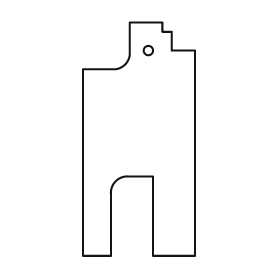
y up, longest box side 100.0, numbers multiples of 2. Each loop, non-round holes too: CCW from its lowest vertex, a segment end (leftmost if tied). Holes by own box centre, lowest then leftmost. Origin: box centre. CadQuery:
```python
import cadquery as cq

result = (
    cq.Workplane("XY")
    .moveTo(-24.0, -50.0)
    .lineTo(-12.0, -50.0)
    .lineTo(-12.0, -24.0)
    .threePointArc((-10.0, -18.0), (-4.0, -16.0))
    .lineTo(6.0, -16.0)
    .lineTo(6.0, -50.0)
    .lineTo(24.0, -50.0)
    .lineTo(24.0, 38.0)
    .lineTo(14.0, 38.0)
    .lineTo(14.0, 46.0)
    .lineTo(10.0, 46.0)
    .lineTo(10.0, 50.0)
    .lineTo(-4.0, 50.0)
    .lineTo(-4.0, 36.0)
    .threePointArc((-6.0, 32.0), (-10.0, 30.0))
    .lineTo(-24.0, 30.0)
    .close()
    .moveTo(4.0, 38.0)
    .circle(2.0)
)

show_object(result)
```